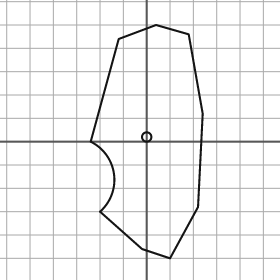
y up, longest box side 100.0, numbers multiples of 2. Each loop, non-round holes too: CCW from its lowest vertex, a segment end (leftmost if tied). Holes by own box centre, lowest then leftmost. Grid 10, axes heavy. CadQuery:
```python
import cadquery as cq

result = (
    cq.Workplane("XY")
    .moveTo(10.0, -50.0)
    .lineTo(22.0, -28.0)
    .lineTo(24.0, 12.0)
    .lineTo(18.0, 46.0)
    .lineTo(4.0, 50.0)
    .lineTo(-12.0, 44.0)
    .lineTo(-24.0, 0.0)
    .threePointArc((-14.0, -14.0), (-20.0, -30.0))
    .lineTo(-2.0, -46.0)
    .close()
    .moveTo(0.0, 2.0)
    .circle(2.0)
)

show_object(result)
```